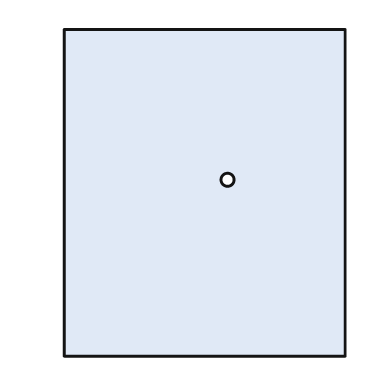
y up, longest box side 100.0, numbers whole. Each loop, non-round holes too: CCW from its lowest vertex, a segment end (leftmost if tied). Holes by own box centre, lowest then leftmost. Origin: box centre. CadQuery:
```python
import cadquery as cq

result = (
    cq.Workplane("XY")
    .moveTo(-43.0, -50.0)
    .lineTo(43.0, -50.0)
    .lineTo(43.0, 50.0)
    .lineTo(-43.0, 50.0)
    .close()
    .moveTo(7.0, 4.0)
    .circle(2.0)
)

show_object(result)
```